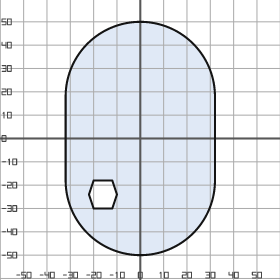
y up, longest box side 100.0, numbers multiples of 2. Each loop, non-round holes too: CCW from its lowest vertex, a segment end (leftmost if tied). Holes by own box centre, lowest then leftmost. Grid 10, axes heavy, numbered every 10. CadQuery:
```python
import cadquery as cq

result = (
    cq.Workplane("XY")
    .moveTo(-32.0, -18.0)
    .threePointArc((0.0, -50.0), (32.0, -18.0))
    .lineTo(32.0, 18.0)
    .threePointArc((0.0, 50.0), (-32.0, 18.0))
    .close()
    .moveTo(-20.0, -30.0)
    .lineTo(-12.0, -30.0)
    .lineTo(-10.0, -24.0)
    .lineTo(-12.0, -18.0)
    .lineTo(-20.0, -18.0)
    .lineTo(-22.0, -24.0)
    .close()
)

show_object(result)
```